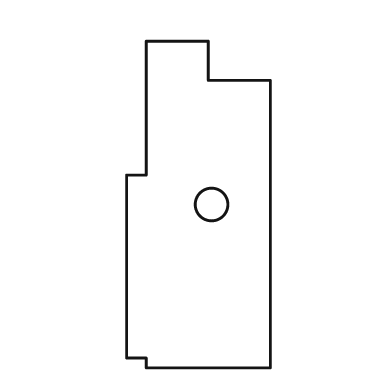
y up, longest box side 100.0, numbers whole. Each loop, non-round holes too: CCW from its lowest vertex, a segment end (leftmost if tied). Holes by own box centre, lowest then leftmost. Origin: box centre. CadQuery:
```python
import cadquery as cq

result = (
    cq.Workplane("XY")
    .moveTo(-16.0, -50.0)
    .lineTo(22.0, -50.0)
    .lineTo(22.0, 38.0)
    .lineTo(3.0, 38.0)
    .lineTo(3.0, 50.0)
    .lineTo(-16.0, 50.0)
    .lineTo(-16.0, 9.0)
    .lineTo(-22.0, 9.0)
    .lineTo(-22.0, -47.0)
    .lineTo(-16.0, -47.0)
    .close()
    .moveTo(4.0, 0.0)
    .circle(5.0)
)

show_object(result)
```